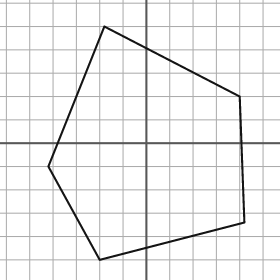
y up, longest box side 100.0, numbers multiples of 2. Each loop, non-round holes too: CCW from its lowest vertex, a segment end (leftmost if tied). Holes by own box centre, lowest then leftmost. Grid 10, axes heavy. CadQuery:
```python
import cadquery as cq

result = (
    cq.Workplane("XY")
    .moveTo(-20.0, -50.0)
    .lineTo(42.0, -34.0)
    .lineTo(40.0, 20.0)
    .lineTo(-18.0, 50.0)
    .lineTo(-42.0, -10.0)
    .close()
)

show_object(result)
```